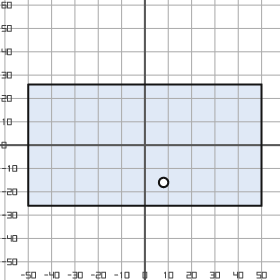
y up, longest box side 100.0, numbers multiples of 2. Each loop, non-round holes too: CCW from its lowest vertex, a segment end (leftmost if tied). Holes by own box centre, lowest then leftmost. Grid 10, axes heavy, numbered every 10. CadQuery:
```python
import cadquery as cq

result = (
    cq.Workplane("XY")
    .moveTo(-50.0, -26.0)
    .lineTo(50.0, -26.0)
    .lineTo(50.0, 26.0)
    .lineTo(-50.0, 26.0)
    .close()
    .moveTo(8.0, -16.0)
    .circle(2.0)
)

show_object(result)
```